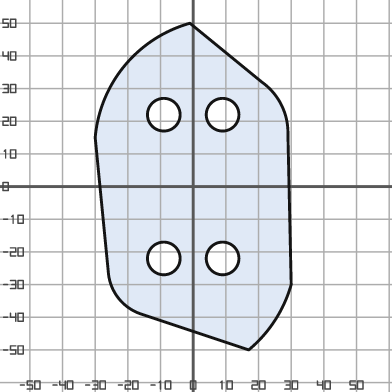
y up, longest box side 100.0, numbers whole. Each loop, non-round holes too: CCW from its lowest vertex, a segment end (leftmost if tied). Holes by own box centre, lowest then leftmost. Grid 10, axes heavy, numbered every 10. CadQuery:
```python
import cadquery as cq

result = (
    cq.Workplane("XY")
    .moveTo(17.0, -50.0)
    .threePointArc((25.0, -41.0), (30.0, -30.0))
    .lineTo(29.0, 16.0)
    .threePointArc((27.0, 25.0), (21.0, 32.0))
    .lineTo(-1.0, 50.0)
    .threePointArc((-21.0, 37.0), (-30.0, 15.0))
    .lineTo(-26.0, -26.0)
    .threePointArc((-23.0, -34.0), (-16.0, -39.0))
    .close()
    .moveTo(-9.0, -22.0)
    .circle(5.0)
    .moveTo(9.0, -22.0)
    .circle(5.0)
    .moveTo(-9.0, 22.0)
    .circle(5.0)
    .moveTo(9.0, 22.0)
    .circle(5.0)
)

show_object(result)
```